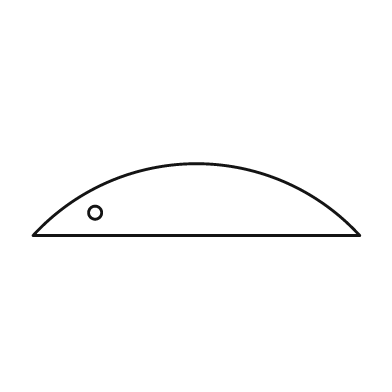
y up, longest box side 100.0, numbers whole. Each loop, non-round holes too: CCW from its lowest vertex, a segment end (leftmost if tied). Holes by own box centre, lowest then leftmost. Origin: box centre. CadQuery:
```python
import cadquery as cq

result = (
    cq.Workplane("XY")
    .moveTo(-50.0, -11.0)
    .lineTo(50.0, -11.0)
    .threePointArc((0.0, 11.0), (-50.0, -11.0))
    .close()
    .moveTo(-31.0, -4.0)
    .circle(2.0)
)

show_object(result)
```